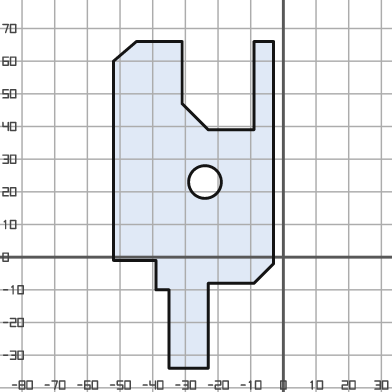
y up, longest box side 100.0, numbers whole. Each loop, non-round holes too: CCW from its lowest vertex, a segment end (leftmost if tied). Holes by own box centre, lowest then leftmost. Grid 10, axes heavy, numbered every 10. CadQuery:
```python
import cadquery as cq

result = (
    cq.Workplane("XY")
    .moveTo(-35.0, -34.0)
    .lineTo(-23.0, -34.0)
    .lineTo(-23.0, -8.0)
    .lineTo(-9.0, -8.0)
    .lineTo(-3.0, -2.0)
    .lineTo(-3.0, 66.0)
    .lineTo(-9.0, 66.0)
    .lineTo(-9.0, 39.0)
    .lineTo(-23.0, 39.0)
    .lineTo(-31.0, 47.0)
    .lineTo(-31.0, 66.0)
    .lineTo(-45.0, 66.0)
    .lineTo(-52.0, 60.0)
    .lineTo(-52.0, -1.0)
    .lineTo(-39.0, -1.0)
    .lineTo(-39.0, -10.0)
    .lineTo(-35.0, -10.0)
    .close()
    .moveTo(-24.0, 23.0)
    .circle(5.0)
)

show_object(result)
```